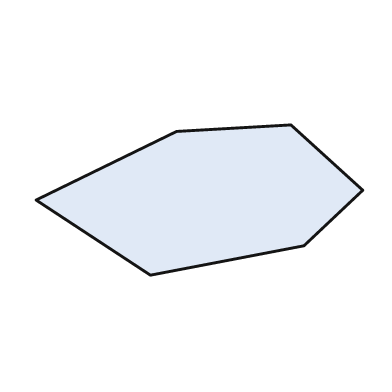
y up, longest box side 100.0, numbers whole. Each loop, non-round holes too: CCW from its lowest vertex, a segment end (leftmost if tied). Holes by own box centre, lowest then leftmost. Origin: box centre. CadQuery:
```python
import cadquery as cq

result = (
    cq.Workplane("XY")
    .moveTo(-15.0, -23.0)
    .lineTo(32.0, -14.0)
    .lineTo(50.0, 3.0)
    .lineTo(28.0, 23.0)
    .lineTo(-7.0, 21.0)
    .lineTo(-50.0, 0.0)
    .close()
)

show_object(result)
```